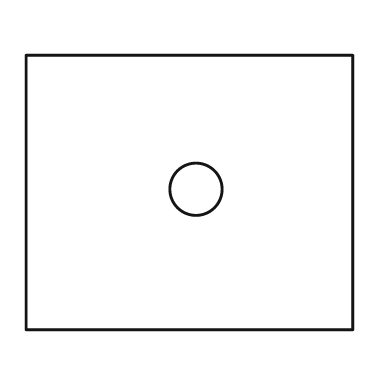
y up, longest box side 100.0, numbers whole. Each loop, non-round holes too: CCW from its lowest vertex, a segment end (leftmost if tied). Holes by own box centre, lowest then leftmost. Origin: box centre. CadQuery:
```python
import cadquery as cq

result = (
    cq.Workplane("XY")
    .moveTo(-50.0, -42.0)
    .lineTo(50.0, -42.0)
    .lineTo(50.0, 42.0)
    .lineTo(-50.0, 42.0)
    .close()
    .moveTo(2.0, 1.0)
    .circle(8.0)
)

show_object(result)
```